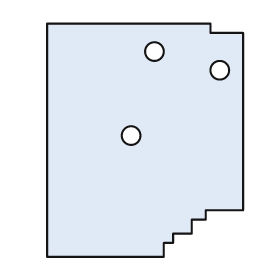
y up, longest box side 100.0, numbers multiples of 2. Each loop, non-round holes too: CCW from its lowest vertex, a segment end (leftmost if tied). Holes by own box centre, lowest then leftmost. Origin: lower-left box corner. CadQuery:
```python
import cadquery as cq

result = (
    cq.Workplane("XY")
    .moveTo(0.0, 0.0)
    .lineTo(50.0, 0.0)
    .lineTo(50.0, 6.0)
    .lineTo(54.0, 6.0)
    .lineTo(54.0, 10.0)
    .lineTo(62.0, 10.0)
    .lineTo(62.0, 16.0)
    .lineTo(68.0, 16.0)
    .lineTo(68.0, 20.0)
    .lineTo(84.0, 20.0)
    .lineTo(84.0, 96.0)
    .lineTo(70.0, 96.0)
    .lineTo(70.0, 100.0)
    .lineTo(0.0, 100.0)
    .close()
    .moveTo(36.0, 52.0)
    .circle(4.0)
    .moveTo(74.0, 80.0)
    .circle(4.0)
    .moveTo(46.0, 88.0)
    .circle(4.0)
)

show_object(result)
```